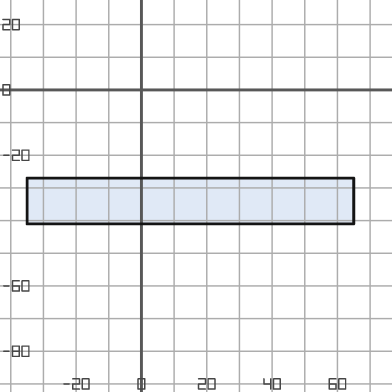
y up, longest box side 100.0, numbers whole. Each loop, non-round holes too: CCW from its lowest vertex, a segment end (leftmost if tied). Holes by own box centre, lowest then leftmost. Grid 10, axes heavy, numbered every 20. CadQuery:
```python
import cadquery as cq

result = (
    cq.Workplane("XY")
    .moveTo(-35.0, -41.0)
    .lineTo(65.0, -41.0)
    .lineTo(65.0, -27.0)
    .lineTo(-35.0, -27.0)
    .close()
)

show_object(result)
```